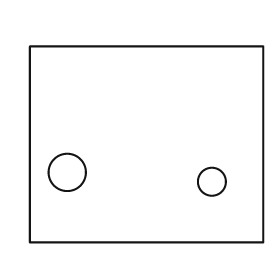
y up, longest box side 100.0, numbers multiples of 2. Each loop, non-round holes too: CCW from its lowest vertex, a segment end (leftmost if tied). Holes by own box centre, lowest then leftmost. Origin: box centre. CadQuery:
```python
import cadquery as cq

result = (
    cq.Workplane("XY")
    .moveTo(-50.0, -42.0)
    .lineTo(50.0, -42.0)
    .lineTo(50.0, 42.0)
    .lineTo(-50.0, 42.0)
    .close()
    .moveTo(28.0, -16.0)
    .circle(6.0)
    .moveTo(-34.0, -12.0)
    .circle(8.0)
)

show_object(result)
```